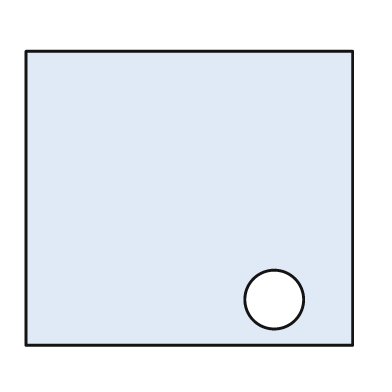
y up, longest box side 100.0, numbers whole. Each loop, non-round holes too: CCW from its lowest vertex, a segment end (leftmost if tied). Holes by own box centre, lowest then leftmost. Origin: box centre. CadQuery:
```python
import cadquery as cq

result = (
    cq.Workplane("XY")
    .moveTo(-50.0, -45.0)
    .lineTo(50.0, -45.0)
    .lineTo(50.0, 45.0)
    .lineTo(-50.0, 45.0)
    .close()
    .moveTo(26.0, -31.0)
    .circle(9.0)
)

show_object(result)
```